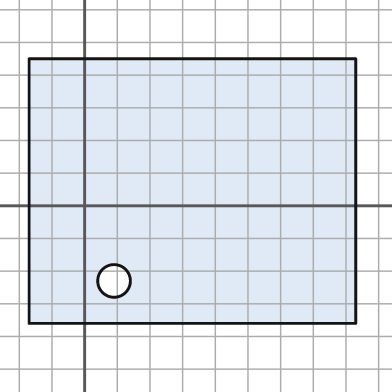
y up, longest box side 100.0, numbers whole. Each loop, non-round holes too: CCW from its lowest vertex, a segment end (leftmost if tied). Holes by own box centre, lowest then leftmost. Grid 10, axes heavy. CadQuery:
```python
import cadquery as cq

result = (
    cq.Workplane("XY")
    .moveTo(-17.0, -36.0)
    .lineTo(83.0, -36.0)
    .lineTo(83.0, 45.0)
    .lineTo(-17.0, 45.0)
    .close()
    .moveTo(9.0, -23.0)
    .circle(5.0)
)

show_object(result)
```